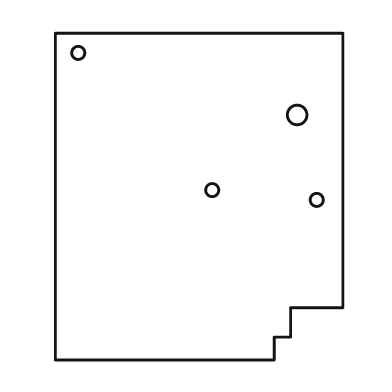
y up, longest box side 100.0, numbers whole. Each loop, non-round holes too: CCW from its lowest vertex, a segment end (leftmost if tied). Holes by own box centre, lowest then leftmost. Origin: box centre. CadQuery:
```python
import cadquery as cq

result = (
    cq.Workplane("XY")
    .moveTo(-44.0, -50.0)
    .lineTo(23.0, -50.0)
    .lineTo(23.0, -43.0)
    .lineTo(28.0, -43.0)
    .lineTo(28.0, -34.0)
    .lineTo(44.0, -34.0)
    .lineTo(44.0, 50.0)
    .lineTo(-44.0, 50.0)
    .close()
    .moveTo(36.0, -1.0)
    .circle(2.0)
    .moveTo(4.0, 2.0)
    .circle(2.0)
    .moveTo(30.0, 25.0)
    .circle(3.0)
    .moveTo(-37.0, 44.0)
    .circle(2.0)
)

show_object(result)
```